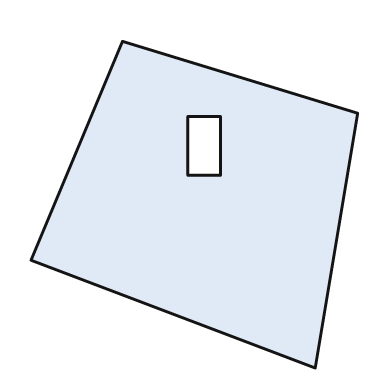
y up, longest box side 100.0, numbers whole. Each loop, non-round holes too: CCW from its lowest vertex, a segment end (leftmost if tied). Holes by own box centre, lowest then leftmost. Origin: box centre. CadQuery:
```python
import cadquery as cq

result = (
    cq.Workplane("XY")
    .moveTo(37.0, -50.0)
    .lineTo(50.0, 28.0)
    .lineTo(-22.0, 50.0)
    .lineTo(-50.0, -17.0)
    .close()
    .moveTo(-2.0, 9.0)
    .lineTo(8.0, 9.0)
    .lineTo(8.0, 27.0)
    .lineTo(-2.0, 27.0)
    .close()
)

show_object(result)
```